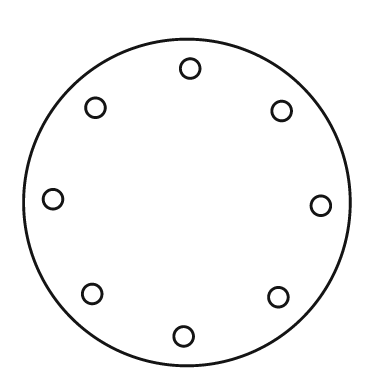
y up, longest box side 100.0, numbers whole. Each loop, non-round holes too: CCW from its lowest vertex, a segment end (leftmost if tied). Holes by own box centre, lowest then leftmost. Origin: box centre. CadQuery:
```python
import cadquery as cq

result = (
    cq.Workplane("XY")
    .moveTo(0.0, 0.0)
    .circle(50.0)
    .moveTo(-1.0, -41.0)
    .circle(3.0)
    .moveTo(28.0, -29.0)
    .circle(3.0)
    .moveTo(-29.0, -28.0)
    .circle(3.0)
    .moveTo(41.0, -1.0)
    .circle(3.0)
    .moveTo(-41.0, 1.0)
    .circle(3.0)
    .moveTo(29.0, 28.0)
    .circle(3.0)
    .moveTo(-28.0, 29.0)
    .circle(3.0)
    .moveTo(1.0, 41.0)
    .circle(3.0)
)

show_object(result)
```